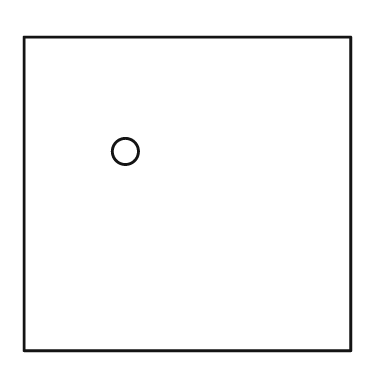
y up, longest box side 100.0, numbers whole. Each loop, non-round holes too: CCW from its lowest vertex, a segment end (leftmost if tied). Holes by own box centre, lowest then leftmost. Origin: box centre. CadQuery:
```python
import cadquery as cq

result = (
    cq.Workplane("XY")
    .moveTo(-50.0, -48.0)
    .lineTo(50.0, -48.0)
    .lineTo(50.0, 48.0)
    .lineTo(-50.0, 48.0)
    .close()
    .moveTo(-19.0, 13.0)
    .circle(4.0)
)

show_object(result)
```